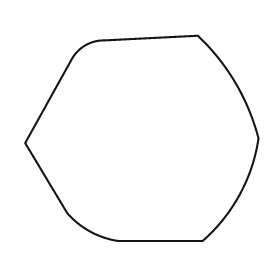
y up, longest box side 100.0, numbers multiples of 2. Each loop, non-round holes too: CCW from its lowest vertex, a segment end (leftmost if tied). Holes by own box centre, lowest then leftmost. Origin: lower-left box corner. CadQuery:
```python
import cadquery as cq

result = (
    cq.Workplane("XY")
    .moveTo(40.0, 0.0)
    .lineTo(76.0, 0.0)
    .threePointArc((92.0, 20.0), (100.0, 44.0))
    .threePointArc((90.0, 68.0), (74.0, 88.0))
    .lineTo(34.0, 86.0)
    .threePointArc((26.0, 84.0), (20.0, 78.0))
    .lineTo(0.0, 42.0)
    .lineTo(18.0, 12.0)
    .threePointArc((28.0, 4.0), (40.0, 0.0))
    .close()
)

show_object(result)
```